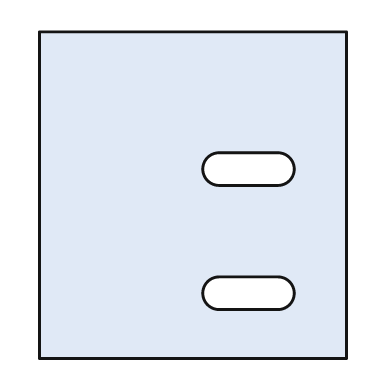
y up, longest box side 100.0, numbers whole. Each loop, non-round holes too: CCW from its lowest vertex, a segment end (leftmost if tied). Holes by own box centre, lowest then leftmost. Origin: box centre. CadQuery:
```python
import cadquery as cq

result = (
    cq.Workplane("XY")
    .moveTo(-47.0, -50.0)
    .lineTo(47.0, -50.0)
    .lineTo(47.0, 50.0)
    .lineTo(-47.0, 50.0)
    .close()
    .moveTo(8.0, -35.0)
    .lineTo(26.0, -35.0)
    .threePointArc((31.0, -30.0), (26.0, -25.0))
    .lineTo(8.0, -25.0)
    .threePointArc((3.0, -30.0), (8.0, -35.0))
    .close()
    .moveTo(8.0, 3.0)
    .lineTo(26.0, 3.0)
    .threePointArc((31.0, 8.0), (26.0, 13.0))
    .lineTo(8.0, 13.0)
    .threePointArc((3.0, 8.0), (8.0, 3.0))
    .close()
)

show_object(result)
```